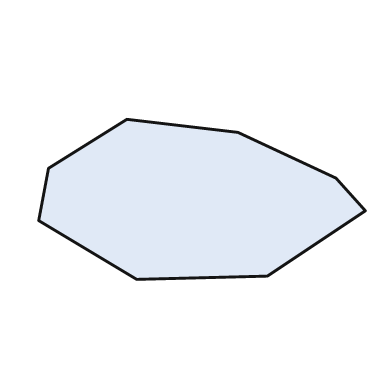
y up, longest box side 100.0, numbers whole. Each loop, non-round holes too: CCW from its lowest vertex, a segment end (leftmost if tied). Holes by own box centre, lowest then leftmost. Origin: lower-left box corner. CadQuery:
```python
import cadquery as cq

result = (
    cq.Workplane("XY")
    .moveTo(30.0, 0.0)
    .lineTo(70.0, 1.0)
    .lineTo(100.0, 21.0)
    .lineTo(91.0, 31.0)
    .lineTo(61.0, 45.0)
    .lineTo(27.0, 49.0)
    .lineTo(3.0, 34.0)
    .lineTo(0.0, 18.0)
    .close()
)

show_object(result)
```